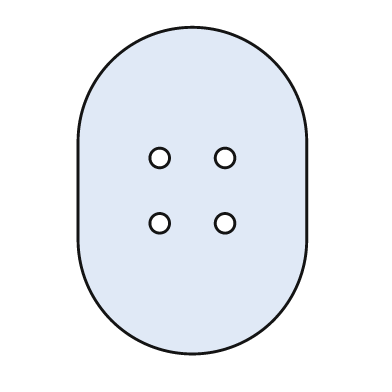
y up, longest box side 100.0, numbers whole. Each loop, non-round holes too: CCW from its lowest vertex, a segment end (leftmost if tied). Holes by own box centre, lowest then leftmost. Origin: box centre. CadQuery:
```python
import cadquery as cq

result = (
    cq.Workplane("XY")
    .moveTo(-35.0, -15.0)
    .threePointArc((0.0, -50.0), (35.0, -15.0))
    .lineTo(35.0, 15.0)
    .threePointArc((0.0, 50.0), (-35.0, 15.0))
    .close()
    .moveTo(-10.0, -10.0)
    .circle(3.0)
    .moveTo(10.0, -10.0)
    .circle(3.0)
    .moveTo(-10.0, 10.0)
    .circle(3.0)
    .moveTo(10.0, 10.0)
    .circle(3.0)
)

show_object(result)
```